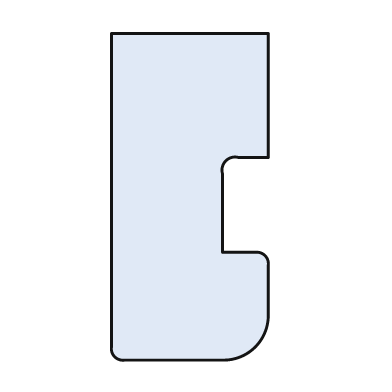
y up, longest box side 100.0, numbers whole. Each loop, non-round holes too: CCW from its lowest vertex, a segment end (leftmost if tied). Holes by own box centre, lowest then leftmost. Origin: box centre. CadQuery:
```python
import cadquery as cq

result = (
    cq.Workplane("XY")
    .moveTo(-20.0, -50.0)
    .lineTo(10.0, -50.0)
    .threePointArc((20.0, -46.0), (24.0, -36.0))
    .lineTo(24.0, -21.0)
    .threePointArc((23.0, -18.0), (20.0, -17.0))
    .lineTo(10.0, -17.0)
    .lineTo(10.0, 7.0)
    .threePointArc((11.0, 11.0), (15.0, 12.0))
    .lineTo(24.0, 12.0)
    .lineTo(24.0, 50.0)
    .lineTo(-24.0, 50.0)
    .lineTo(-24.0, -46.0)
    .threePointArc((-23.0, -49.0), (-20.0, -50.0))
    .close()
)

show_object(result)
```